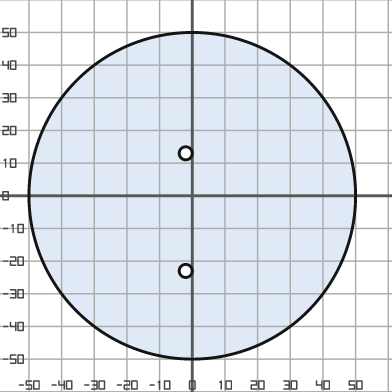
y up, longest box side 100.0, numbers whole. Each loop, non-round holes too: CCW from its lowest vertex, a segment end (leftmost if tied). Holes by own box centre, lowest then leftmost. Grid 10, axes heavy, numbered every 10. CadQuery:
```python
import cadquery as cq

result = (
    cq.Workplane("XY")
    .moveTo(0.0, 0.0)
    .circle(50.0)
    .moveTo(-2.0, -23.0)
    .circle(2.0)
    .moveTo(-2.0, 13.0)
    .circle(2.0)
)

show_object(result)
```